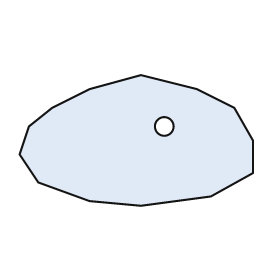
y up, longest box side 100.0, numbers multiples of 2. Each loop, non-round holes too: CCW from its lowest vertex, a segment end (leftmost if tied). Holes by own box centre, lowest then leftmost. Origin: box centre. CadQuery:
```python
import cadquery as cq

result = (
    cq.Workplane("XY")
    .moveTo(2.0, -28.0)
    .lineTo(32.0, -24.0)
    .lineTo(50.0, -14.0)
    .lineTo(50.0, 0.0)
    .lineTo(42.0, 14.0)
    .lineTo(26.0, 22.0)
    .lineTo(2.0, 28.0)
    .lineTo(-20.0, 22.0)
    .lineTo(-36.0, 14.0)
    .lineTo(-46.0, 6.0)
    .lineTo(-50.0, -6.0)
    .lineTo(-42.0, -18.0)
    .lineTo(-20.0, -26.0)
    .close()
    .moveTo(12.0, 6.0)
    .circle(4.0)
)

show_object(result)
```